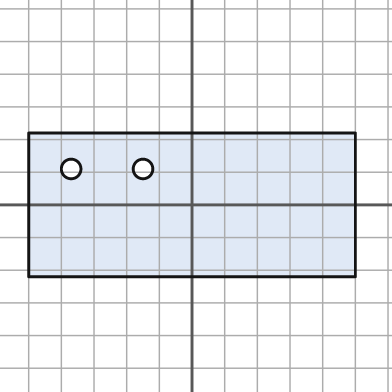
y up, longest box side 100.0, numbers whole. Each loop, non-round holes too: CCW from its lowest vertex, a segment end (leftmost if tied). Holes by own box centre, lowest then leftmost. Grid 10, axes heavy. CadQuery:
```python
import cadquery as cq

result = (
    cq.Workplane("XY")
    .moveTo(-50.0, -22.0)
    .lineTo(50.0, -22.0)
    .lineTo(50.0, 22.0)
    .lineTo(-50.0, 22.0)
    .close()
    .moveTo(-37.0, 11.0)
    .circle(3.0)
    .moveTo(-15.0, 11.0)
    .circle(3.0)
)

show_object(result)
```